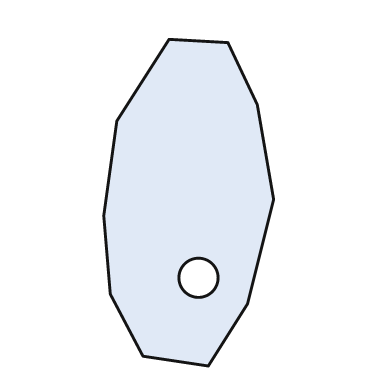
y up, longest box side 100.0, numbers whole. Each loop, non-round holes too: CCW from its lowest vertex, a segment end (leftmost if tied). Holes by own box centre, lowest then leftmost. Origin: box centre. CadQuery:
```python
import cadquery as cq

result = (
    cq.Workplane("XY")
    .moveTo(6.0, -50.0)
    .lineTo(18.0, -31.0)
    .lineTo(26.0, 1.0)
    .lineTo(21.0, 30.0)
    .lineTo(12.0, 49.0)
    .lineTo(-6.0, 50.0)
    .lineTo(-22.0, 25.0)
    .lineTo(-26.0, -4.0)
    .lineTo(-24.0, -28.0)
    .lineTo(-14.0, -47.0)
    .close()
    .moveTo(3.0, -23.0)
    .circle(6.0)
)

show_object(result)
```